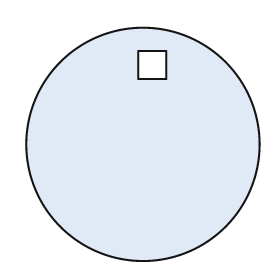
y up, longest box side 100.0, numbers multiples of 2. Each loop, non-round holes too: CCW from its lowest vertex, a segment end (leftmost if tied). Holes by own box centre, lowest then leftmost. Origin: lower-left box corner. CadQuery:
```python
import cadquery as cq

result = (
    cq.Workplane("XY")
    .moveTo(50.0, 50.0)
    .circle(50.0)
    .moveTo(48.0, 78.0)
    .lineTo(60.0, 78.0)
    .lineTo(60.0, 90.0)
    .lineTo(48.0, 90.0)
    .close()
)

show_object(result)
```